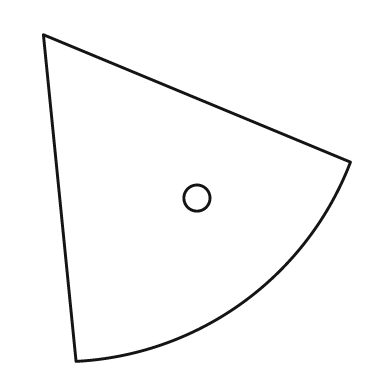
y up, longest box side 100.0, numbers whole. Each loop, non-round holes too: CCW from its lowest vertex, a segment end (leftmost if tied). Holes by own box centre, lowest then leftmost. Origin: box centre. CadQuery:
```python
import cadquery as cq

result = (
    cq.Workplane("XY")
    .moveTo(-37.0, -50.0)
    .threePointArc((14.0, -32.0), (47.0, 11.0))
    .lineTo(-47.0, 50.0)
    .close()
    .moveTo(0.0, 0.0)
    .circle(4.0)
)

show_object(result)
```